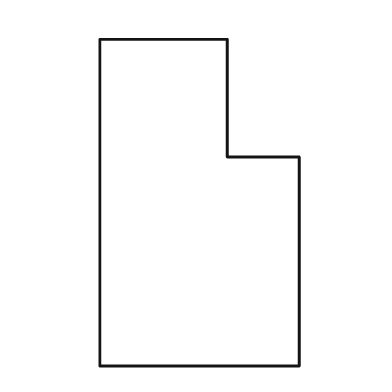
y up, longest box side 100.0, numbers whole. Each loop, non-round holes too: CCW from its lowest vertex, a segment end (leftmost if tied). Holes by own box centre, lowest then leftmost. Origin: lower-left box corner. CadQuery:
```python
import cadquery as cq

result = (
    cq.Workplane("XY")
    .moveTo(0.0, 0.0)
    .lineTo(61.0, 0.0)
    .lineTo(61.0, 64.0)
    .lineTo(39.0, 64.0)
    .lineTo(39.0, 100.0)
    .lineTo(0.0, 100.0)
    .close()
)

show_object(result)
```